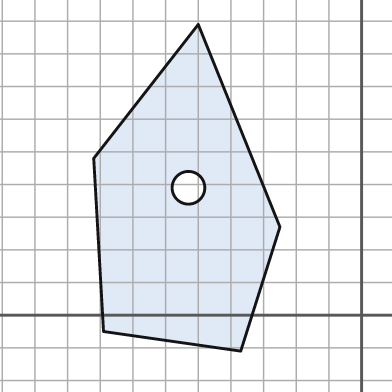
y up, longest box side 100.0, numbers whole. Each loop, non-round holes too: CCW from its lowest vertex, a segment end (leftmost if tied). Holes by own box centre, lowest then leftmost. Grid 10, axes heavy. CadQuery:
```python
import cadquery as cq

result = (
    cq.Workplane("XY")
    .moveTo(-37.0, -11.0)
    .lineTo(-25.0, 27.0)
    .lineTo(-50.0, 89.0)
    .lineTo(-82.0, 48.0)
    .lineTo(-79.0, -5.0)
    .close()
    .moveTo(-53.0, 39.0)
    .circle(5.0)
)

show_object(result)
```